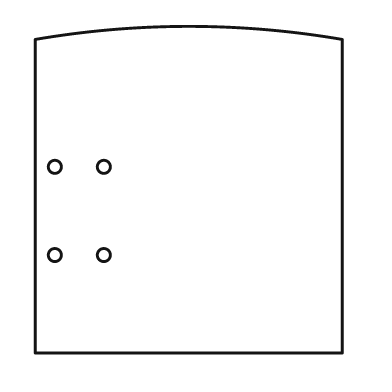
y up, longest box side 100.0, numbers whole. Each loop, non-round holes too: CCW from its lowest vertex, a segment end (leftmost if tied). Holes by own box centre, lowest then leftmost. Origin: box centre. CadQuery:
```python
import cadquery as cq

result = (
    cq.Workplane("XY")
    .moveTo(-47.0, -50.0)
    .lineTo(47.0, -50.0)
    .lineTo(47.0, 46.0)
    .threePointArc((0.0, 50.0), (-47.0, 46.0))
    .close()
    .moveTo(-41.0, -20.0)
    .circle(2.0)
    .moveTo(-26.0, -20.0)
    .circle(2.0)
    .moveTo(-41.0, 7.0)
    .circle(2.0)
    .moveTo(-26.0, 7.0)
    .circle(2.0)
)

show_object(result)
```